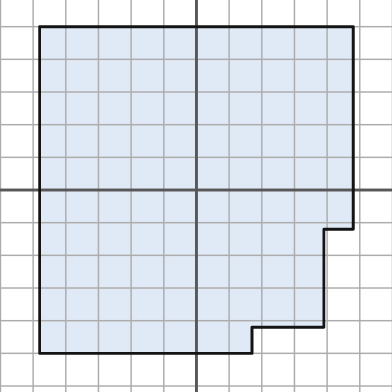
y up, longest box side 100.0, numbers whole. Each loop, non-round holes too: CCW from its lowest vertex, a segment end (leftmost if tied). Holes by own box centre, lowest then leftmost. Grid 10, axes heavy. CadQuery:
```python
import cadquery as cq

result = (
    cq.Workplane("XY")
    .moveTo(-48.0, -50.0)
    .lineTo(17.0, -50.0)
    .lineTo(17.0, -42.0)
    .lineTo(39.0, -42.0)
    .lineTo(39.0, -12.0)
    .lineTo(48.0, -12.0)
    .lineTo(48.0, 50.0)
    .lineTo(-48.0, 50.0)
    .close()
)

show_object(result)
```